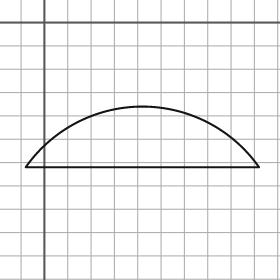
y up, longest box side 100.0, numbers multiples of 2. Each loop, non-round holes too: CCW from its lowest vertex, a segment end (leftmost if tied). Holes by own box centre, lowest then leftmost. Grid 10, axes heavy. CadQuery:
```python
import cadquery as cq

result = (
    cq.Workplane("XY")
    .moveTo(-8.0, -62.0)
    .lineTo(92.0, -62.0)
    .threePointArc((42.0, -36.0), (-8.0, -62.0))
    .close()
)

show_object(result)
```